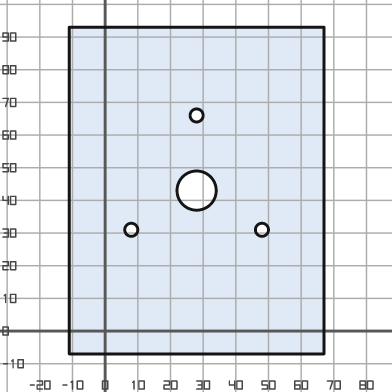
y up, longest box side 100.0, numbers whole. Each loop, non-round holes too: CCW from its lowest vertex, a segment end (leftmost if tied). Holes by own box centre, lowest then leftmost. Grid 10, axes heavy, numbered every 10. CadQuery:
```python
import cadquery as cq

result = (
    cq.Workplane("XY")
    .moveTo(-11.0, -7.0)
    .lineTo(67.0, -7.0)
    .lineTo(67.0, 93.0)
    .lineTo(-11.0, 93.0)
    .close()
    .moveTo(8.0, 31.0)
    .circle(2.0)
    .moveTo(48.0, 31.0)
    .circle(2.0)
    .moveTo(28.0, 43.0)
    .circle(6.0)
    .moveTo(28.0, 66.0)
    .circle(2.0)
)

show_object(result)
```